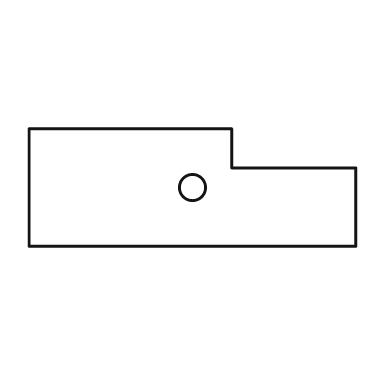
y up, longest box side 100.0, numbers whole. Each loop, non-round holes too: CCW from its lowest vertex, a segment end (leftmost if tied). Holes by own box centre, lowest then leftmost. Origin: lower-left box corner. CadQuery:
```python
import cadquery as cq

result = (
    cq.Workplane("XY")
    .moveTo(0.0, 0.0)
    .lineTo(100.0, 0.0)
    .lineTo(100.0, 24.0)
    .lineTo(62.0, 24.0)
    .lineTo(62.0, 36.0)
    .lineTo(0.0, 36.0)
    .close()
    .moveTo(50.0, 18.0)
    .circle(4.0)
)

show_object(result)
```